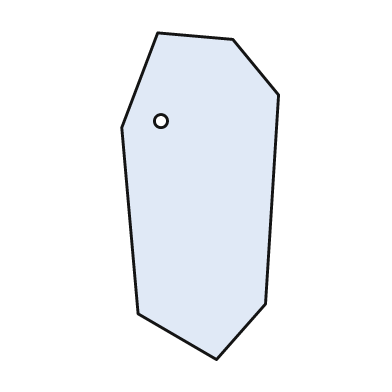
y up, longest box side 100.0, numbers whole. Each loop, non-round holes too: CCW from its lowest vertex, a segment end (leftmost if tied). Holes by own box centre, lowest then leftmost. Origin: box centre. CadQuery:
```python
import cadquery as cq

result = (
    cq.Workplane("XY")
    .moveTo(5.0, -50.0)
    .lineTo(20.0, -33.0)
    .lineTo(24.0, 31.0)
    .lineTo(10.0, 48.0)
    .lineTo(-13.0, 50.0)
    .lineTo(-24.0, 21.0)
    .lineTo(-19.0, -36.0)
    .close()
    .moveTo(-12.0, 23.0)
    .circle(2.0)
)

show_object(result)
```